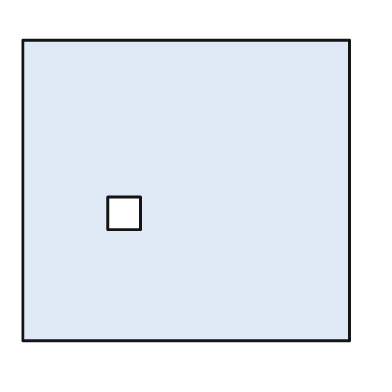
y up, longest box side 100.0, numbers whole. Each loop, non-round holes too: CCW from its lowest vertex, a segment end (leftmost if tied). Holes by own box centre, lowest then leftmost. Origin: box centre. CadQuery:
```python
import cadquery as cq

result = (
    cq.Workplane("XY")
    .moveTo(-50.0, -46.0)
    .lineTo(50.0, -46.0)
    .lineTo(50.0, 46.0)
    .lineTo(-50.0, 46.0)
    .close()
    .moveTo(-24.0, -12.0)
    .lineTo(-14.0, -12.0)
    .lineTo(-14.0, -2.0)
    .lineTo(-24.0, -2.0)
    .close()
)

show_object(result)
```